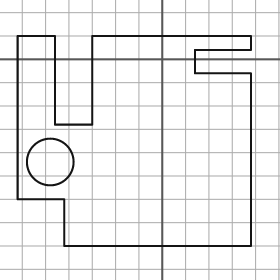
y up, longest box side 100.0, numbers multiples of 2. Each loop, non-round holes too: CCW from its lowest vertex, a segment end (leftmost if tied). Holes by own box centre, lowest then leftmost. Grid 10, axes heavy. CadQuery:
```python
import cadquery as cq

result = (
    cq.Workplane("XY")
    .moveTo(-42.0, -80.0)
    .lineTo(38.0, -80.0)
    .lineTo(38.0, -6.0)
    .lineTo(14.0, -6.0)
    .lineTo(14.0, 4.0)
    .lineTo(38.0, 4.0)
    .lineTo(38.0, 10.0)
    .lineTo(-30.0, 10.0)
    .lineTo(-30.0, -28.0)
    .lineTo(-46.0, -28.0)
    .lineTo(-46.0, 10.0)
    .lineTo(-62.0, 10.0)
    .lineTo(-62.0, -60.0)
    .lineTo(-42.0, -60.0)
    .close()
    .moveTo(-48.0, -44.0)
    .circle(10.0)
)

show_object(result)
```